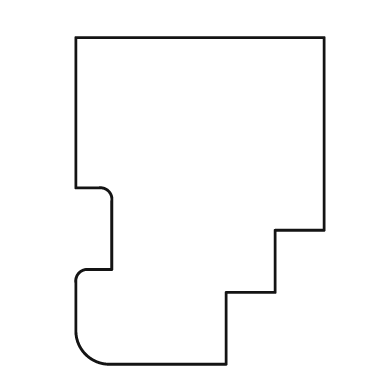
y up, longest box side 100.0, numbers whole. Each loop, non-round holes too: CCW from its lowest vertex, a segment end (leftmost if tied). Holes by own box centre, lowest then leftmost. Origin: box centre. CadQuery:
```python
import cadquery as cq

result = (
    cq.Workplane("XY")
    .moveTo(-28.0, -50.0)
    .lineTo(8.0, -50.0)
    .lineTo(8.0, -28.0)
    .lineTo(23.0, -28.0)
    .lineTo(23.0, -9.0)
    .lineTo(38.0, -9.0)
    .lineTo(38.0, 50.0)
    .lineTo(-38.0, 50.0)
    .lineTo(-38.0, 4.0)
    .lineTo(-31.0, 4.0)
    .threePointArc((-28.0, 3.0), (-27.0, 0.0))
    .lineTo(-27.0, -21.0)
    .lineTo(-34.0, -21.0)
    .threePointArc((-37.0, -22.0), (-38.0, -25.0))
    .lineTo(-38.0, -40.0)
    .threePointArc((-35.0, -47.0), (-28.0, -50.0))
    .close()
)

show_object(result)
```